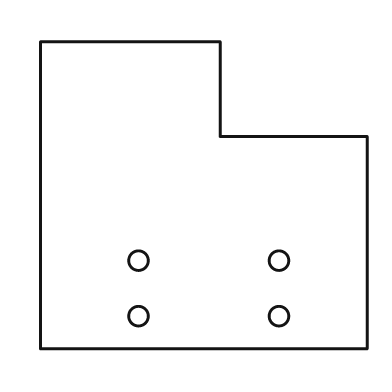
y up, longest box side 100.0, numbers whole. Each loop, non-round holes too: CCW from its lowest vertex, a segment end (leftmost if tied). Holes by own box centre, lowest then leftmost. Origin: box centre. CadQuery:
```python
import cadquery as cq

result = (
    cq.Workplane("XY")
    .moveTo(-50.0, -47.0)
    .lineTo(50.0, -47.0)
    .lineTo(50.0, 18.0)
    .lineTo(5.0, 18.0)
    .lineTo(5.0, 47.0)
    .lineTo(-50.0, 47.0)
    .close()
    .moveTo(-20.0, -37.0)
    .circle(3.0)
    .moveTo(23.0, -37.0)
    .circle(3.0)
    .moveTo(-20.0, -20.0)
    .circle(3.0)
    .moveTo(23.0, -20.0)
    .circle(3.0)
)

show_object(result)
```